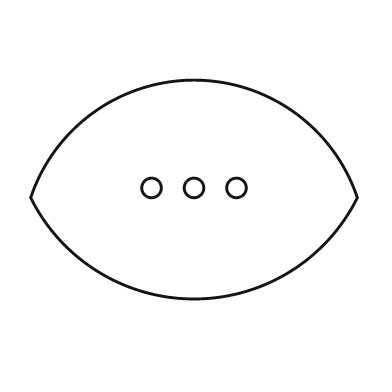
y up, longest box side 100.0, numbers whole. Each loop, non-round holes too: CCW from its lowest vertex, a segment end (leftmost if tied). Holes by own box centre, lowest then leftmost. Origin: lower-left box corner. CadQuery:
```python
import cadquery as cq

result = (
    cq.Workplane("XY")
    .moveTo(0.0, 31.0)
    .threePointArc((50.0, 0.0), (100.0, 31.0))
    .threePointArc((50.0, 67.0), (0.0, 31.0))
    .close()
    .moveTo(37.0, 34.0)
    .circle(3.0)
    .moveTo(50.0, 34.0)
    .circle(3.0)
    .moveTo(63.0, 34.0)
    .circle(3.0)
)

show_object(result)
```